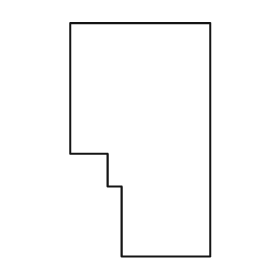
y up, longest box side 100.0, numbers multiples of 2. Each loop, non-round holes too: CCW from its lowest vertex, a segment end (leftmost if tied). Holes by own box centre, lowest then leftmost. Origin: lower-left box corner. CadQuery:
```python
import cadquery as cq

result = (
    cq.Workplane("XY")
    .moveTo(22.0, 0.0)
    .lineTo(60.0, 0.0)
    .lineTo(60.0, 100.0)
    .lineTo(0.0, 100.0)
    .lineTo(0.0, 44.0)
    .lineTo(16.0, 44.0)
    .lineTo(16.0, 30.0)
    .lineTo(22.0, 30.0)
    .close()
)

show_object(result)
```